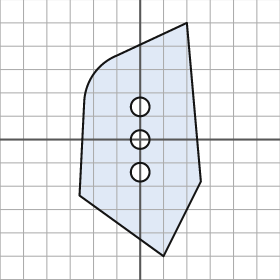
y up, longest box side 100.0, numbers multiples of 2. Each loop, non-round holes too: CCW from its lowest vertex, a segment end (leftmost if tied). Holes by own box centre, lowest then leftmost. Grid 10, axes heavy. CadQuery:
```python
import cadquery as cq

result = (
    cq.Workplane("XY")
    .moveTo(10.0, -50.0)
    .lineTo(26.0, -18.0)
    .lineTo(20.0, 50.0)
    .lineTo(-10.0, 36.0)
    .threePointArc((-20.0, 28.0), (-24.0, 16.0))
    .lineTo(-26.0, -24.0)
    .close()
    .moveTo(0.0, -14.0)
    .circle(4.0)
    .moveTo(0.0, 0.0)
    .circle(4.0)
    .moveTo(0.0, 14.0)
    .circle(4.0)
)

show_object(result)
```